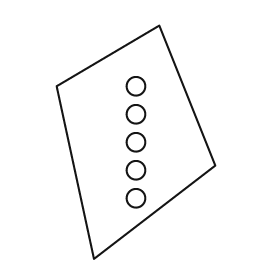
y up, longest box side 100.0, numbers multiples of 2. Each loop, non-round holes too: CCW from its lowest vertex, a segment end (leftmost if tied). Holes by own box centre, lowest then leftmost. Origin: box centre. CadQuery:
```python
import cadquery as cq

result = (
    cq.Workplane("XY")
    .moveTo(-18.0, -50.0)
    .lineTo(34.0, -10.0)
    .lineTo(10.0, 50.0)
    .lineTo(-34.0, 24.0)
    .close()
    .moveTo(0.0, -24.0)
    .circle(4.0)
    .moveTo(0.0, -12.0)
    .circle(4.0)
    .moveTo(0.0, 0.0)
    .circle(4.0)
    .moveTo(0.0, 12.0)
    .circle(4.0)
    .moveTo(0.0, 24.0)
    .circle(4.0)
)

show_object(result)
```